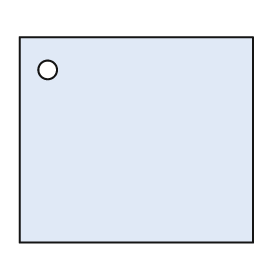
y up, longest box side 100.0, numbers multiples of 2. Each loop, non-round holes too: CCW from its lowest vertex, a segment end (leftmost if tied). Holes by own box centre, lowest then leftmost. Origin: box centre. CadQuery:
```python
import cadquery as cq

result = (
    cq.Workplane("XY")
    .moveTo(-50.0, -44.0)
    .lineTo(50.0, -44.0)
    .lineTo(50.0, 44.0)
    .lineTo(-50.0, 44.0)
    .close()
    .moveTo(-38.0, 30.0)
    .circle(4.0)
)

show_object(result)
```